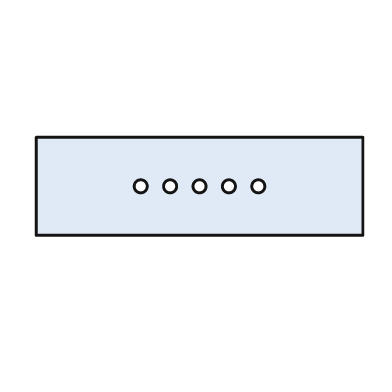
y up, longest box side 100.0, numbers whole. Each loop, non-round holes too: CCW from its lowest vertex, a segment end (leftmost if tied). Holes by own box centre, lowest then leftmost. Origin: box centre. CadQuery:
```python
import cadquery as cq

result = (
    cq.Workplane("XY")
    .moveTo(-50.0, -15.0)
    .lineTo(50.0, -15.0)
    .lineTo(50.0, 15.0)
    .lineTo(-50.0, 15.0)
    .close()
    .moveTo(-18.0, 0.0)
    .circle(2.0)
    .moveTo(-9.0, 0.0)
    .circle(2.0)
    .moveTo(0.0, 0.0)
    .circle(2.0)
    .moveTo(9.0, 0.0)
    .circle(2.0)
    .moveTo(18.0, 0.0)
    .circle(2.0)
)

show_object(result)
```